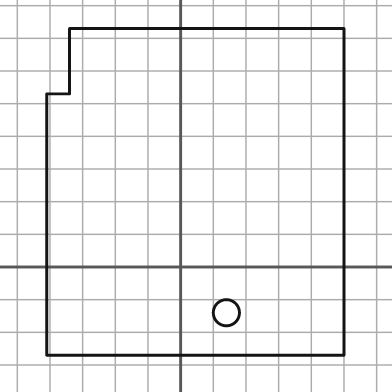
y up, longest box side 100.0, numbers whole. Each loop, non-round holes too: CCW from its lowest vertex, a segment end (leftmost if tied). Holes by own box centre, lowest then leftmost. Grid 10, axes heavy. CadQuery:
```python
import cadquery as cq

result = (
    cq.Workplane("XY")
    .moveTo(-41.0, -27.0)
    .lineTo(50.0, -27.0)
    .lineTo(50.0, 73.0)
    .lineTo(-34.0, 73.0)
    .lineTo(-34.0, 53.0)
    .lineTo(-41.0, 53.0)
    .close()
    .moveTo(14.0, -14.0)
    .circle(4.0)
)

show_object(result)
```